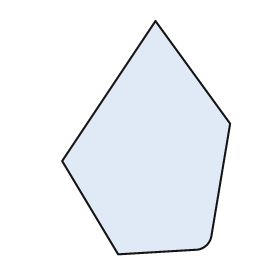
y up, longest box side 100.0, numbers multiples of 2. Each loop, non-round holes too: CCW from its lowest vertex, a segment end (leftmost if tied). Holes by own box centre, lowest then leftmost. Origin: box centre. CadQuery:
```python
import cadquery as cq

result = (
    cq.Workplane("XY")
    .moveTo(-12.0, -50.0)
    .lineTo(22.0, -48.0)
    .threePointArc((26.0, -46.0), (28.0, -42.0))
    .lineTo(36.0, 6.0)
    .lineTo(4.0, 50.0)
    .lineTo(-36.0, -10.0)
    .close()
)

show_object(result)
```